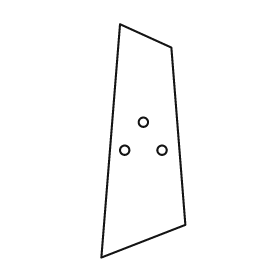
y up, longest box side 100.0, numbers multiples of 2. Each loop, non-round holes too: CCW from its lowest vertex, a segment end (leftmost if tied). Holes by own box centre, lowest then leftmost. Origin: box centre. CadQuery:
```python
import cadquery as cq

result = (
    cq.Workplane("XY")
    .moveTo(-18.0, -50.0)
    .lineTo(18.0, -36.0)
    .lineTo(12.0, 40.0)
    .lineTo(-10.0, 50.0)
    .close()
    .moveTo(-8.0, -4.0)
    .circle(2.0)
    .moveTo(8.0, -4.0)
    .circle(2.0)
    .moveTo(0.0, 8.0)
    .circle(2.0)
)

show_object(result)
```